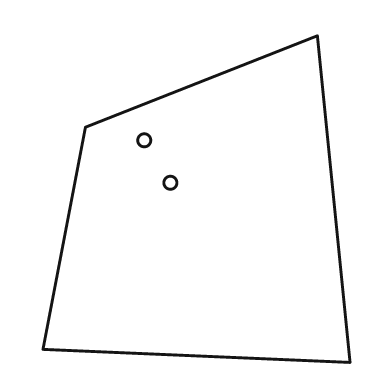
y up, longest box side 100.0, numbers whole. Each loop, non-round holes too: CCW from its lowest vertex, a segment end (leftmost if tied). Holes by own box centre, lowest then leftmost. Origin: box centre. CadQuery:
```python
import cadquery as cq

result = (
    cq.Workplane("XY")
    .moveTo(47.0, -50.0)
    .lineTo(37.0, 50.0)
    .lineTo(-34.0, 22.0)
    .lineTo(-47.0, -46.0)
    .close()
    .moveTo(-8.0, 5.0)
    .circle(2.0)
    .moveTo(-16.0, 18.0)
    .circle(2.0)
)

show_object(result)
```